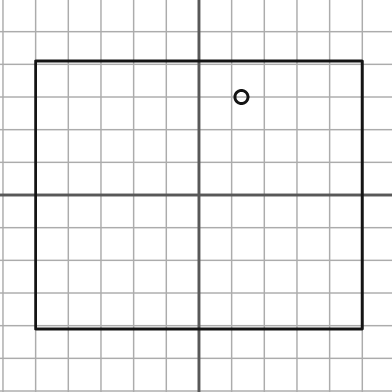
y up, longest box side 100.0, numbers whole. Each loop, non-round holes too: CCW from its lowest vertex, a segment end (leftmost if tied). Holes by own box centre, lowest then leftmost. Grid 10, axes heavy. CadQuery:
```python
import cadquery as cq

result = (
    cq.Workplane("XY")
    .moveTo(-50.0, -41.0)
    .lineTo(50.0, -41.0)
    .lineTo(50.0, 41.0)
    .lineTo(-50.0, 41.0)
    .close()
    .moveTo(13.0, 30.0)
    .circle(2.0)
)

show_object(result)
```